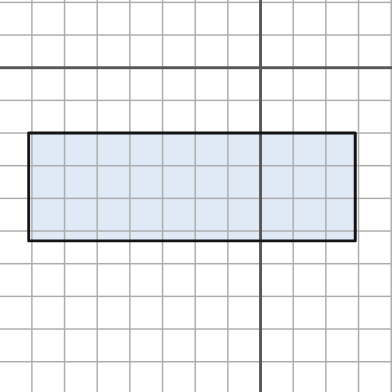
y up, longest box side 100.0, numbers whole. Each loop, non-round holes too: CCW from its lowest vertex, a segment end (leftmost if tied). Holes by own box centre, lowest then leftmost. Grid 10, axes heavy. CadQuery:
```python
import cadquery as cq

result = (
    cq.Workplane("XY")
    .moveTo(-71.0, -53.0)
    .lineTo(29.0, -53.0)
    .lineTo(29.0, -20.0)
    .lineTo(-71.0, -20.0)
    .close()
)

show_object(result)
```